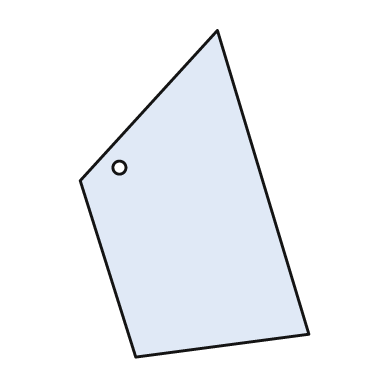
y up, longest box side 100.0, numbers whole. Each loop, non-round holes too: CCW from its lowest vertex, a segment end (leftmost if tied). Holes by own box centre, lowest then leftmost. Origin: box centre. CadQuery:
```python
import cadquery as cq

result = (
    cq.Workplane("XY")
    .moveTo(-18.0, -50.0)
    .lineTo(35.0, -43.0)
    .lineTo(7.0, 50.0)
    .lineTo(-35.0, 4.0)
    .close()
    .moveTo(-23.0, 8.0)
    .circle(2.0)
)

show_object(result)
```